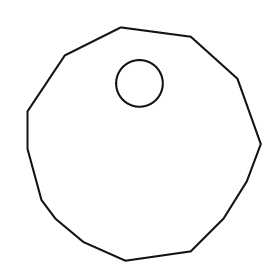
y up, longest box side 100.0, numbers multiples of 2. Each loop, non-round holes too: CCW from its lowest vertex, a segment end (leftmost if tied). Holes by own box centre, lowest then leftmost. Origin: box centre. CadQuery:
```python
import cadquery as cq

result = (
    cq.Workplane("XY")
    .moveTo(-8.0, -50.0)
    .lineTo(20.0, -46.0)
    .lineTo(34.0, -32.0)
    .lineTo(44.0, -16.0)
    .lineTo(50.0, 0.0)
    .lineTo(40.0, 28.0)
    .lineTo(20.0, 46.0)
    .lineTo(-10.0, 50.0)
    .lineTo(-34.0, 38.0)
    .lineTo(-50.0, 14.0)
    .lineTo(-50.0, -2.0)
    .lineTo(-44.0, -24.0)
    .lineTo(-38.0, -32.0)
    .lineTo(-26.0, -42.0)
    .close()
    .moveTo(-2.0, 26.0)
    .circle(10.0)
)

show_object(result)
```